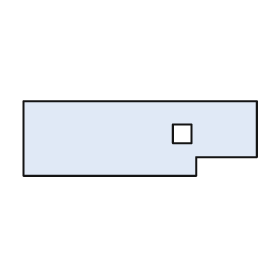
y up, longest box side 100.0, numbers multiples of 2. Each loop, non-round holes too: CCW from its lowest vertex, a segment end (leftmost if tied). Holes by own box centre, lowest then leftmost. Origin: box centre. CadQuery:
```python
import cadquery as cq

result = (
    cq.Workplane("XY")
    .moveTo(-50.0, -16.0)
    .lineTo(24.0, -16.0)
    .lineTo(24.0, -8.0)
    .lineTo(50.0, -8.0)
    .lineTo(50.0, 16.0)
    .lineTo(-50.0, 16.0)
    .close()
    .moveTo(14.0, -2.0)
    .lineTo(22.0, -2.0)
    .lineTo(22.0, 6.0)
    .lineTo(14.0, 6.0)
    .close()
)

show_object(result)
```